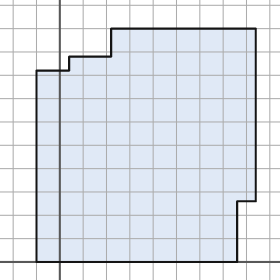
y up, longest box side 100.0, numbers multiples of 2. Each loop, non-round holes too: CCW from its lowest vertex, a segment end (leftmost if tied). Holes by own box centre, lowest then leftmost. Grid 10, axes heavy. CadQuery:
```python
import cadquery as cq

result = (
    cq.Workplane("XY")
    .moveTo(-10.0, 0.0)
    .lineTo(76.0, 0.0)
    .lineTo(76.0, 26.0)
    .lineTo(84.0, 26.0)
    .lineTo(84.0, 100.0)
    .lineTo(22.0, 100.0)
    .lineTo(22.0, 88.0)
    .lineTo(4.0, 88.0)
    .lineTo(4.0, 82.0)
    .lineTo(-10.0, 82.0)
    .close()
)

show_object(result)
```